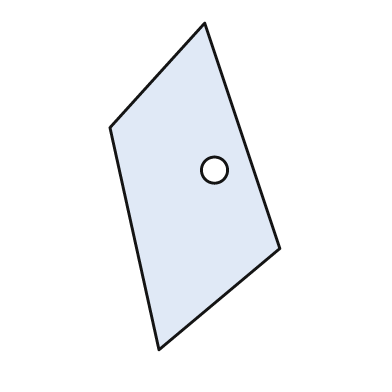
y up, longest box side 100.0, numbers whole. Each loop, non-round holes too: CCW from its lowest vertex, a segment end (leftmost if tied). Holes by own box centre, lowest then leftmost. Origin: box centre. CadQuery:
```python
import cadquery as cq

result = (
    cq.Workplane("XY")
    .moveTo(-11.0, -50.0)
    .lineTo(26.0, -19.0)
    .lineTo(3.0, 50.0)
    .lineTo(-26.0, 18.0)
    .close()
    .moveTo(6.0, 5.0)
    .circle(4.0)
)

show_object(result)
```